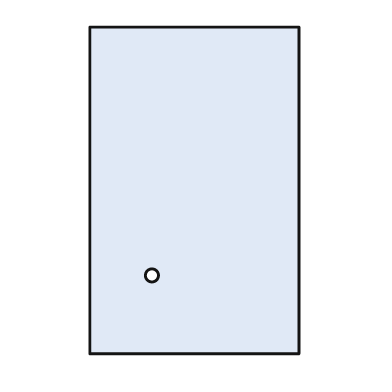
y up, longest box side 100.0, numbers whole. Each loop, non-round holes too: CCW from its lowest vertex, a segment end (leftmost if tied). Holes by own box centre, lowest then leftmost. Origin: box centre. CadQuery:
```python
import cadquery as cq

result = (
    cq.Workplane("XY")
    .moveTo(-32.0, -50.0)
    .lineTo(32.0, -50.0)
    .lineTo(32.0, 50.0)
    .lineTo(-32.0, 50.0)
    .close()
    .moveTo(-13.0, -26.0)
    .circle(2.0)
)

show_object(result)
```